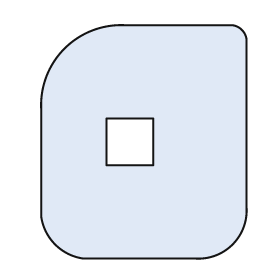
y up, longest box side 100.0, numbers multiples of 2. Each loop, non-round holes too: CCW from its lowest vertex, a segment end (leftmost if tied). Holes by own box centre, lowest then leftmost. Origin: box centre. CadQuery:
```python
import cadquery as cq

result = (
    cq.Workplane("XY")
    .moveTo(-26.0, -50.0)
    .lineTo(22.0, -50.0)
    .threePointArc((38.0, -44.0), (44.0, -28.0))
    .lineTo(44.0, 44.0)
    .threePointArc((42.0, 48.0), (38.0, 50.0))
    .lineTo(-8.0, 50.0)
    .threePointArc((-34.0, 40.0), (-44.0, 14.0))
    .lineTo(-44.0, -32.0)
    .threePointArc((-38.0, -44.0), (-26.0, -50.0))
    .close()
    .moveTo(-16.0, -10.0)
    .lineTo(4.0, -10.0)
    .lineTo(4.0, 10.0)
    .lineTo(-16.0, 10.0)
    .close()
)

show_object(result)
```